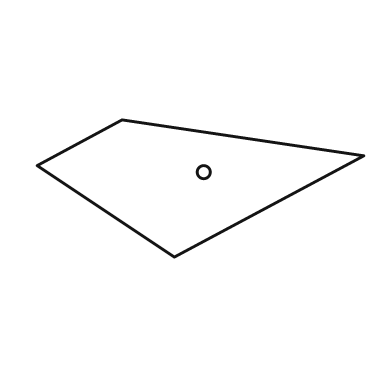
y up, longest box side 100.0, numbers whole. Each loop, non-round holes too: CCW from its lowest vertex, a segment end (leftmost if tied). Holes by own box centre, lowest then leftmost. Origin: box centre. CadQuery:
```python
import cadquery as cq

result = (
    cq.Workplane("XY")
    .moveTo(-8.0, -21.0)
    .lineTo(50.0, 10.0)
    .lineTo(-24.0, 21.0)
    .lineTo(-50.0, 7.0)
    .close()
    .moveTo(1.0, 5.0)
    .circle(2.0)
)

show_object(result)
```